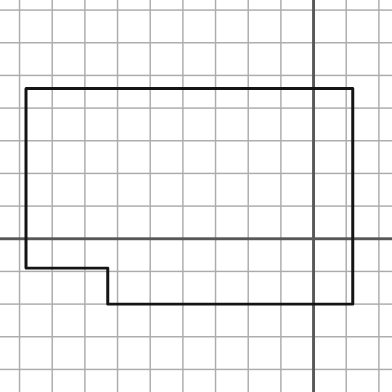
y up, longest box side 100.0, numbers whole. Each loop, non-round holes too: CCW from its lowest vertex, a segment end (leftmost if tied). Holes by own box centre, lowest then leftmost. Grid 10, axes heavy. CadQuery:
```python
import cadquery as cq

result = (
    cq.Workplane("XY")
    .moveTo(-63.0, -20.0)
    .lineTo(12.0, -20.0)
    .lineTo(12.0, 46.0)
    .lineTo(-88.0, 46.0)
    .lineTo(-88.0, -9.0)
    .lineTo(-63.0, -9.0)
    .close()
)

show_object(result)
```